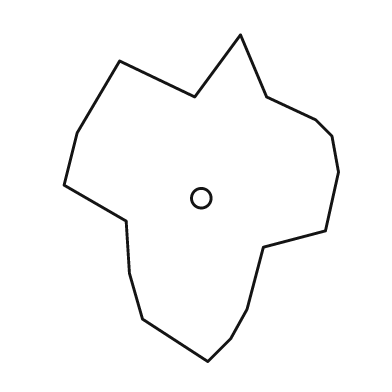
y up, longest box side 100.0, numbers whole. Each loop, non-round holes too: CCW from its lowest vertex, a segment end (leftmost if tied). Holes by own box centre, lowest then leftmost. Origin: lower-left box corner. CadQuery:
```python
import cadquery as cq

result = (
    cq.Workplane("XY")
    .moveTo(44.0, 0.0)
    .lineTo(51.0, 7.0)
    .lineTo(56.0, 16.0)
    .lineTo(61.0, 35.0)
    .lineTo(80.0, 40.0)
    .lineTo(84.0, 58.0)
    .lineTo(82.0, 69.0)
    .lineTo(77.0, 74.0)
    .lineTo(62.0, 81.0)
    .lineTo(54.0, 100.0)
    .lineTo(40.0, 81.0)
    .lineTo(17.0, 92.0)
    .lineTo(4.0, 70.0)
    .lineTo(0.0, 54.0)
    .lineTo(19.0, 43.0)
    .lineTo(20.0, 27.0)
    .lineTo(24.0, 13.0)
    .close()
    .moveTo(42.0, 50.0)
    .circle(3.0)
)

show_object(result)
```